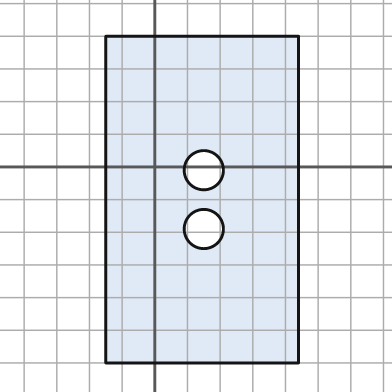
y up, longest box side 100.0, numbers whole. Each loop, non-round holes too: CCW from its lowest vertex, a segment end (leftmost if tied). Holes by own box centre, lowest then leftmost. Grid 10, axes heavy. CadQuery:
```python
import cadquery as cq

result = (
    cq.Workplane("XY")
    .moveTo(-15.0, -60.0)
    .lineTo(44.0, -60.0)
    .lineTo(44.0, 40.0)
    .lineTo(-15.0, 40.0)
    .close()
    .moveTo(15.0, -19.0)
    .circle(6.0)
    .moveTo(15.0, -1.0)
    .circle(6.0)
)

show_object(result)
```